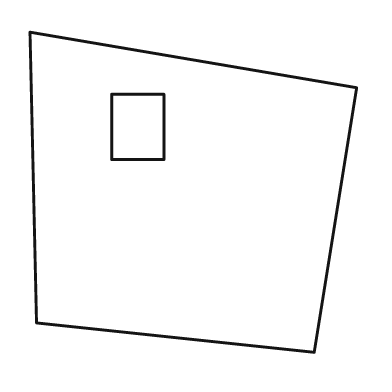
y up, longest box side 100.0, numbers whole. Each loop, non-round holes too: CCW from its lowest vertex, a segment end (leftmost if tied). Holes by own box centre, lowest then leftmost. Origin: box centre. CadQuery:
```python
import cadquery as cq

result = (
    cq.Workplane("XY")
    .moveTo(37.0, -49.0)
    .lineTo(50.0, 32.0)
    .lineTo(-50.0, 49.0)
    .lineTo(-48.0, -40.0)
    .close()
    .moveTo(-25.0, 10.0)
    .lineTo(-9.0, 10.0)
    .lineTo(-9.0, 30.0)
    .lineTo(-25.0, 30.0)
    .close()
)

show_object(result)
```